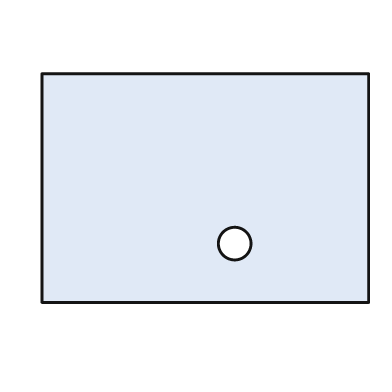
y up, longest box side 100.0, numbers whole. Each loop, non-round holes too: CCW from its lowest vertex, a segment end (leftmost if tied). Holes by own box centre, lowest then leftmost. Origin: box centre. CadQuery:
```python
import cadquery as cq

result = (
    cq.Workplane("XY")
    .moveTo(-50.0, -35.0)
    .lineTo(50.0, -35.0)
    .lineTo(50.0, 35.0)
    .lineTo(-50.0, 35.0)
    .close()
    .moveTo(9.0, -17.0)
    .circle(5.0)
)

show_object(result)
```